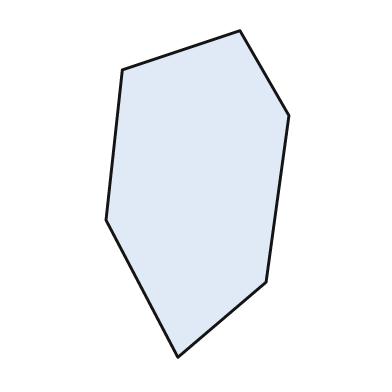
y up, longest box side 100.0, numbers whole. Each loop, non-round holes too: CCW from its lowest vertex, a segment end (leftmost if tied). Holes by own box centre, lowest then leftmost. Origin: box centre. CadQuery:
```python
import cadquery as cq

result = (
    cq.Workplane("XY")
    .moveTo(-6.0, -50.0)
    .lineTo(21.0, -27.0)
    .lineTo(28.0, 24.0)
    .lineTo(13.0, 50.0)
    .lineTo(-23.0, 38.0)
    .lineTo(-28.0, -8.0)
    .close()
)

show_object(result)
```